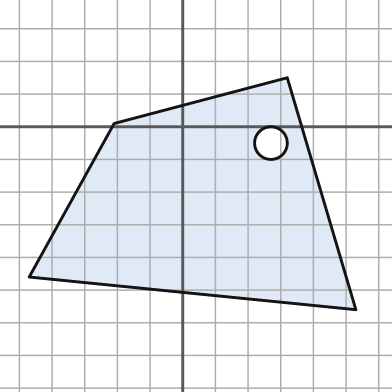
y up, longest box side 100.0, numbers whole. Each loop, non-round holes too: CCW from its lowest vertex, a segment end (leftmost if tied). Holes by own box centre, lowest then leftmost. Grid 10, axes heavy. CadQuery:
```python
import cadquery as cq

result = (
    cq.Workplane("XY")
    .moveTo(53.0, -56.0)
    .lineTo(32.0, 15.0)
    .lineTo(-21.0, 1.0)
    .lineTo(-47.0, -46.0)
    .close()
    .moveTo(27.0, -5.0)
    .circle(5.0)
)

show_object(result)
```